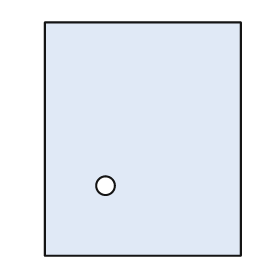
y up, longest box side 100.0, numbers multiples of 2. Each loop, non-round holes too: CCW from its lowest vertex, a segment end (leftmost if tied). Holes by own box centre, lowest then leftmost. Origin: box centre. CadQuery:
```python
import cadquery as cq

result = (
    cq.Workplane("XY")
    .moveTo(-42.0, -50.0)
    .lineTo(42.0, -50.0)
    .lineTo(42.0, 50.0)
    .lineTo(-42.0, 50.0)
    .close()
    .moveTo(-16.0, -20.0)
    .circle(4.0)
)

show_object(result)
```